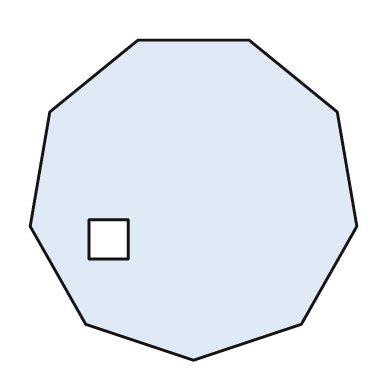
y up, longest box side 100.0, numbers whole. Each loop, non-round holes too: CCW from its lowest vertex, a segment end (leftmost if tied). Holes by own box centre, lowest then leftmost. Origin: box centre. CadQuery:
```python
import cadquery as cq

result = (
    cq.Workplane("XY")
    .moveTo(0.0, -49.0)
    .lineTo(33.0, -38.0)
    .lineTo(50.0, -8.0)
    .lineTo(44.0, 27.0)
    .lineTo(17.0, 49.0)
    .lineTo(-17.0, 49.0)
    .lineTo(-44.0, 27.0)
    .lineTo(-50.0, -8.0)
    .lineTo(-33.0, -38.0)
    .close()
    .moveTo(-32.0, -18.0)
    .lineTo(-20.0, -18.0)
    .lineTo(-20.0, -6.0)
    .lineTo(-32.0, -6.0)
    .close()
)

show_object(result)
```